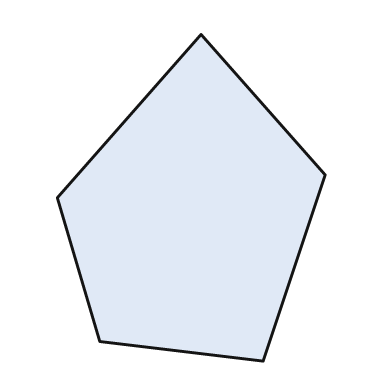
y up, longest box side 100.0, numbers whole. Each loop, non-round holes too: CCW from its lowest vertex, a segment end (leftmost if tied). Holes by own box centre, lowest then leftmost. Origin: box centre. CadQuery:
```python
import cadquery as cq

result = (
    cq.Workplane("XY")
    .moveTo(22.0, -50.0)
    .lineTo(41.0, 7.0)
    .lineTo(3.0, 50.0)
    .lineTo(-41.0, 0.0)
    .lineTo(-28.0, -44.0)
    .close()
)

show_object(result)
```